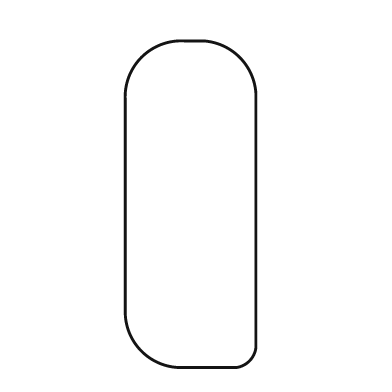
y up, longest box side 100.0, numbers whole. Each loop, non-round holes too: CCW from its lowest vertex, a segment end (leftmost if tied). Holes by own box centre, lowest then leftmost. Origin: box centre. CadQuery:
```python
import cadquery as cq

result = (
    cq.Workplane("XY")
    .moveTo(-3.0, -50.0)
    .lineTo(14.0, -50.0)
    .threePointArc((18.0, -48.0), (20.0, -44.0))
    .lineTo(20.0, 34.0)
    .threePointArc((15.0, 45.0), (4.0, 50.0))
    .lineTo(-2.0, 50.0)
    .threePointArc((-15.0, 45.0), (-20.0, 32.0))
    .lineTo(-20.0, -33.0)
    .threePointArc((-15.0, -45.0), (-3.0, -50.0))
    .close()
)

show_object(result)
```